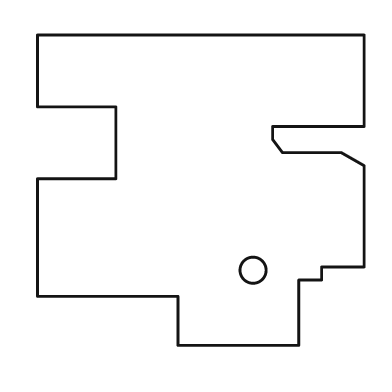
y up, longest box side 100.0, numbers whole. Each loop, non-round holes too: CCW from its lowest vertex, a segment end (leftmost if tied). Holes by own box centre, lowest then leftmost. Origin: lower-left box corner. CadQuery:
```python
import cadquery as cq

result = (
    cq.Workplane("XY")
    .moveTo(43.0, 0.0)
    .lineTo(80.0, 0.0)
    .lineTo(80.0, 20.0)
    .lineTo(87.0, 20.0)
    .lineTo(87.0, 24.0)
    .lineTo(100.0, 24.0)
    .lineTo(100.0, 55.0)
    .lineTo(93.0, 59.0)
    .lineTo(75.0, 59.0)
    .lineTo(72.0, 63.0)
    .lineTo(72.0, 67.0)
    .lineTo(100.0, 67.0)
    .lineTo(100.0, 95.0)
    .lineTo(0.0, 95.0)
    .lineTo(0.0, 73.0)
    .lineTo(24.0, 73.0)
    .lineTo(24.0, 51.0)
    .lineTo(0.0, 51.0)
    .lineTo(0.0, 15.0)
    .lineTo(43.0, 15.0)
    .close()
    .moveTo(66.0, 23.0)
    .circle(4.0)
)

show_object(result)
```